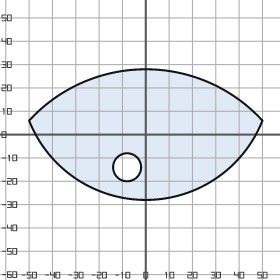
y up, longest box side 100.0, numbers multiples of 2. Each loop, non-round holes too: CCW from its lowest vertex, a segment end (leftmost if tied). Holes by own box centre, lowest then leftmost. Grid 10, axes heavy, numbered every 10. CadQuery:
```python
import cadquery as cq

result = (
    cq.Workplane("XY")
    .moveTo(-50.0, 6.0)
    .threePointArc((0.0, -28.0), (50.0, 6.0))
    .threePointArc((0.0, 28.0), (-50.0, 6.0))
    .close()
    .moveTo(-8.0, -14.0)
    .circle(6.0)
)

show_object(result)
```